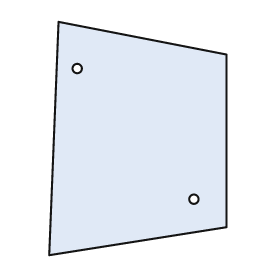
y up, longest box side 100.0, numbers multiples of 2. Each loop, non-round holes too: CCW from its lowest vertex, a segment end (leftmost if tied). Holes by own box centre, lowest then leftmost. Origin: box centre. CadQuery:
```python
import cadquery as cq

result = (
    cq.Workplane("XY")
    .moveTo(-38.0, -50.0)
    .lineTo(38.0, -38.0)
    .lineTo(38.0, 36.0)
    .lineTo(-34.0, 50.0)
    .close()
    .moveTo(24.0, -26.0)
    .circle(2.0)
    .moveTo(-26.0, 30.0)
    .circle(2.0)
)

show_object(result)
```